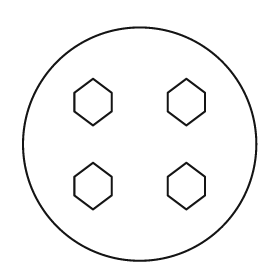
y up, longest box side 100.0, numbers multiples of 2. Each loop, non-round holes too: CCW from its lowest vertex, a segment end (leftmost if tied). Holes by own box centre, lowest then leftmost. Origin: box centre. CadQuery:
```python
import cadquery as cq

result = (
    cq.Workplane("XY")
    .moveTo(0.0, 0.0)
    .circle(50.0)
    .moveTo(-20.0, -28.0)
    .lineTo(-12.0, -22.0)
    .lineTo(-12.0, -14.0)
    .lineTo(-20.0, -8.0)
    .lineTo(-28.0, -14.0)
    .lineTo(-28.0, -22.0)
    .close()
    .moveTo(20.0, -28.0)
    .lineTo(28.0, -22.0)
    .lineTo(28.0, -14.0)
    .lineTo(20.0, -8.0)
    .lineTo(12.0, -14.0)
    .lineTo(12.0, -22.0)
    .close()
    .moveTo(-20.0, 8.0)
    .lineTo(-12.0, 14.0)
    .lineTo(-12.0, 22.0)
    .lineTo(-20.0, 28.0)
    .lineTo(-28.0, 22.0)
    .lineTo(-28.0, 14.0)
    .close()
    .moveTo(20.0, 8.0)
    .lineTo(28.0, 14.0)
    .lineTo(28.0, 22.0)
    .lineTo(20.0, 28.0)
    .lineTo(12.0, 22.0)
    .lineTo(12.0, 14.0)
    .close()
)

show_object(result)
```